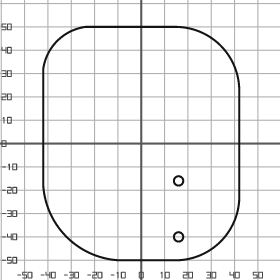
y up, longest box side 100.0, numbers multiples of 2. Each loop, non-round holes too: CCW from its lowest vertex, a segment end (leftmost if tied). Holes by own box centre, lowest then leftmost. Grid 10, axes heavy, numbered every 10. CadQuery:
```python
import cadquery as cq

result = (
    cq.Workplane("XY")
    .moveTo(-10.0, -50.0)
    .lineTo(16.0, -50.0)
    .threePointArc((34.0, -42.0), (42.0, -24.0))
    .lineTo(42.0, 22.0)
    .threePointArc((34.0, 42.0), (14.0, 50.0))
    .lineTo(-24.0, 50.0)
    .threePointArc((-36.0, 44.0), (-42.0, 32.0))
    .lineTo(-42.0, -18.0)
    .threePointArc((-32.0, -40.0), (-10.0, -50.0))
    .close()
    .moveTo(16.0, -40.0)
    .circle(2.0)
    .moveTo(16.0, -16.0)
    .circle(2.0)
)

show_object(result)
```